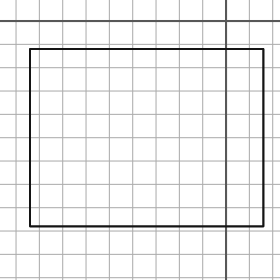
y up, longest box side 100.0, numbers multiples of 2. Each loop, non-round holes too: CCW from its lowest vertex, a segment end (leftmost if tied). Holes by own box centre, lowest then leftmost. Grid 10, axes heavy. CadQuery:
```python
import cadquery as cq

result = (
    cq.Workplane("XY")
    .moveTo(-84.0, -88.0)
    .lineTo(16.0, -88.0)
    .lineTo(16.0, -12.0)
    .lineTo(-84.0, -12.0)
    .close()
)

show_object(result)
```